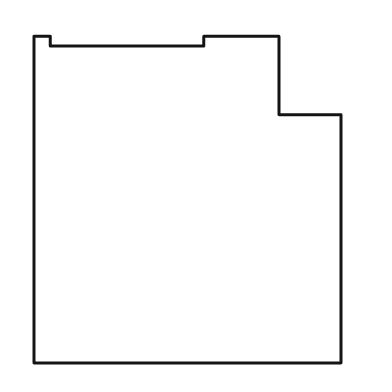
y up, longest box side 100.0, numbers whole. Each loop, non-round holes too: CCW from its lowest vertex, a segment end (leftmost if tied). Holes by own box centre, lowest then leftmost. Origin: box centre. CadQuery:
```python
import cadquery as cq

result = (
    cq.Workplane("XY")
    .moveTo(-47.0, -50.0)
    .lineTo(47.0, -50.0)
    .lineTo(47.0, 26.0)
    .lineTo(28.0, 26.0)
    .lineTo(28.0, 50.0)
    .lineTo(5.0, 50.0)
    .lineTo(5.0, 47.0)
    .lineTo(-42.0, 47.0)
    .lineTo(-42.0, 50.0)
    .lineTo(-47.0, 50.0)
    .close()
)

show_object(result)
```